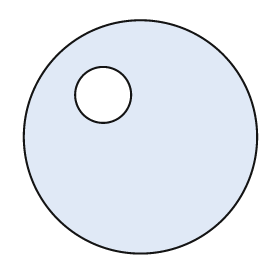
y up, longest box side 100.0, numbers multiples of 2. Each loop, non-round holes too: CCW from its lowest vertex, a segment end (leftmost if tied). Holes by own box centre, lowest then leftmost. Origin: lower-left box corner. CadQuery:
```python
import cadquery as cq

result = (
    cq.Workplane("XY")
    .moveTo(50.0, 50.0)
    .circle(50.0)
    .moveTo(34.0, 68.0)
    .circle(12.0)
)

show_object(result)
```